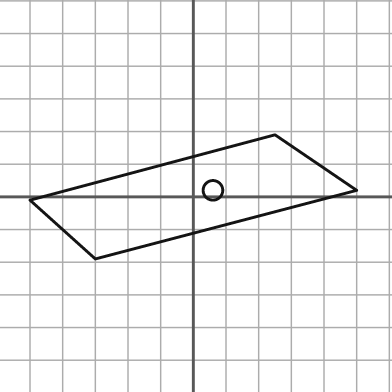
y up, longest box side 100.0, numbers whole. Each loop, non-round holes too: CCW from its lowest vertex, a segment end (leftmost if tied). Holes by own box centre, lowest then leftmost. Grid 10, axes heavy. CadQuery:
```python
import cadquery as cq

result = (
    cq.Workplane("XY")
    .moveTo(-30.0, -19.0)
    .lineTo(50.0, 2.0)
    .lineTo(25.0, 19.0)
    .lineTo(-50.0, -1.0)
    .close()
    .moveTo(6.0, 2.0)
    .circle(3.0)
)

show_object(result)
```